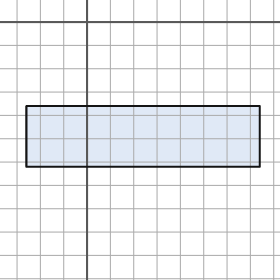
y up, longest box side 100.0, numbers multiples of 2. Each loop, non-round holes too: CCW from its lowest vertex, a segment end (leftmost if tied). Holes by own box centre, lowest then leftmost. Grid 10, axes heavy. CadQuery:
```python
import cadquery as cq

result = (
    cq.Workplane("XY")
    .moveTo(-26.0, -62.0)
    .lineTo(74.0, -62.0)
    .lineTo(74.0, -36.0)
    .lineTo(-26.0, -36.0)
    .close()
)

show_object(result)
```